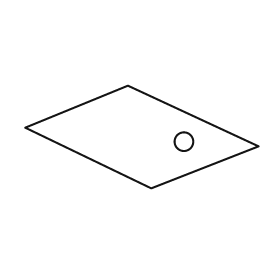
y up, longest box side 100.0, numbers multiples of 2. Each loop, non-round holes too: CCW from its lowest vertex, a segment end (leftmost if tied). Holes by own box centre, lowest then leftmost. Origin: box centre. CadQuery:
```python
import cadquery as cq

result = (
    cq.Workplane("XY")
    .moveTo(4.0, -22.0)
    .lineTo(50.0, -4.0)
    .lineTo(-6.0, 22.0)
    .lineTo(-50.0, 4.0)
    .close()
    .moveTo(18.0, -2.0)
    .circle(4.0)
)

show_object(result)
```